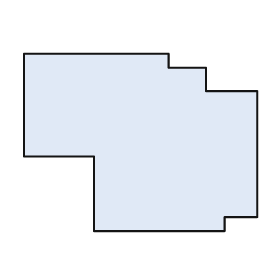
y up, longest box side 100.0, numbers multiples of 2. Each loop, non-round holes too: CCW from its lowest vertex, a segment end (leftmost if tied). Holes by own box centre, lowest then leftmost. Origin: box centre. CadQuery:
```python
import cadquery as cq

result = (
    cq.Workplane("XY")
    .moveTo(-20.0, -38.0)
    .lineTo(36.0, -38.0)
    .lineTo(36.0, -32.0)
    .lineTo(50.0, -32.0)
    .lineTo(50.0, 22.0)
    .lineTo(28.0, 22.0)
    .lineTo(28.0, 32.0)
    .lineTo(12.0, 32.0)
    .lineTo(12.0, 38.0)
    .lineTo(-50.0, 38.0)
    .lineTo(-50.0, -6.0)
    .lineTo(-20.0, -6.0)
    .close()
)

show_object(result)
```